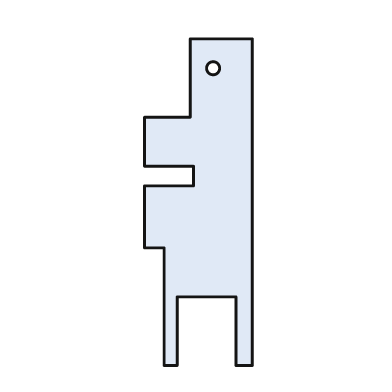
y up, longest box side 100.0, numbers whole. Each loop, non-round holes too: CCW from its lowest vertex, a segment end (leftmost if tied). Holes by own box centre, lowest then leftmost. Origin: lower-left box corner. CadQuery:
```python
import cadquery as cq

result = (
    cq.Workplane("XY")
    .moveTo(6.0, 0.0)
    .lineTo(10.0, 0.0)
    .lineTo(10.0, 21.0)
    .lineTo(28.0, 21.0)
    .lineTo(28.0, 0.0)
    .lineTo(33.0, 0.0)
    .lineTo(33.0, 100.0)
    .lineTo(14.0, 100.0)
    .lineTo(14.0, 76.0)
    .lineTo(0.0, 76.0)
    .lineTo(0.0, 61.0)
    .lineTo(15.0, 61.0)
    .lineTo(15.0, 55.0)
    .lineTo(0.0, 55.0)
    .lineTo(0.0, 36.0)
    .lineTo(6.0, 36.0)
    .close()
    .moveTo(21.0, 91.0)
    .circle(2.0)
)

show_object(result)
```